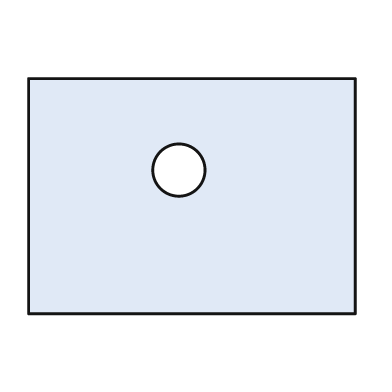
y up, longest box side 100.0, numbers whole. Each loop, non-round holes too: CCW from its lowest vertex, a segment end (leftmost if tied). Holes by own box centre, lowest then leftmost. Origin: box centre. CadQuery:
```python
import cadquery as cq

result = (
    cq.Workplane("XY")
    .moveTo(-50.0, -36.0)
    .lineTo(50.0, -36.0)
    .lineTo(50.0, 36.0)
    .lineTo(-50.0, 36.0)
    .close()
    .moveTo(-4.0, 8.0)
    .circle(8.0)
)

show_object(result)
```